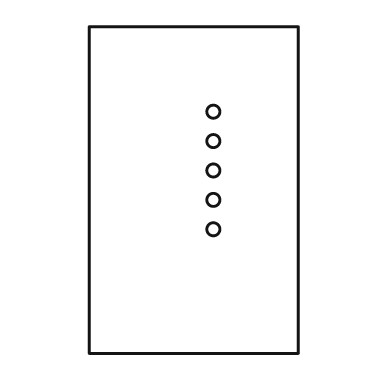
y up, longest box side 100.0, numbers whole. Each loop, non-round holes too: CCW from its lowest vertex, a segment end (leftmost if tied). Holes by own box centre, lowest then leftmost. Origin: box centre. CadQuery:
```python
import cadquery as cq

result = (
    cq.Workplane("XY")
    .moveTo(-32.0, -50.0)
    .lineTo(32.0, -50.0)
    .lineTo(32.0, 50.0)
    .lineTo(-32.0, 50.0)
    .close()
    .moveTo(6.0, -12.0)
    .circle(2.0)
    .moveTo(6.0, -3.0)
    .circle(2.0)
    .moveTo(6.0, 6.0)
    .circle(2.0)
    .moveTo(6.0, 15.0)
    .circle(2.0)
    .moveTo(6.0, 24.0)
    .circle(2.0)
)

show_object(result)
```